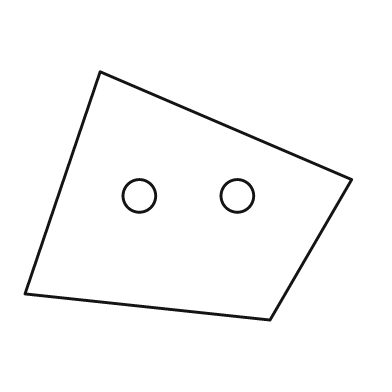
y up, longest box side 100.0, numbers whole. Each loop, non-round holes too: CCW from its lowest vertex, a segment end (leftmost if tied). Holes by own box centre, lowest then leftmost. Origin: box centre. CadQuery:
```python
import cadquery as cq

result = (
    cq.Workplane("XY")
    .moveTo(25.0, -38.0)
    .lineTo(50.0, 5.0)
    .lineTo(-27.0, 38.0)
    .lineTo(-50.0, -30.0)
    .close()
    .moveTo(-15.0, 0.0)
    .circle(5.0)
    .moveTo(15.0, 0.0)
    .circle(5.0)
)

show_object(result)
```